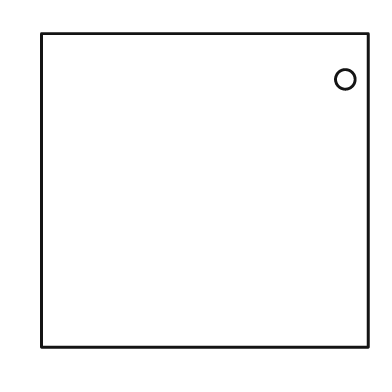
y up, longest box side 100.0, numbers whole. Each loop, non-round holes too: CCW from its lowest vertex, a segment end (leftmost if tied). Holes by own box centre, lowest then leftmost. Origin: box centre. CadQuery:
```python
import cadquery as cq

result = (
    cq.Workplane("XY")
    .moveTo(-50.0, -48.0)
    .lineTo(50.0, -48.0)
    .lineTo(50.0, 48.0)
    .lineTo(-50.0, 48.0)
    .close()
    .moveTo(43.0, 34.0)
    .circle(3.0)
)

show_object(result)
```